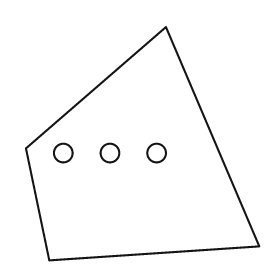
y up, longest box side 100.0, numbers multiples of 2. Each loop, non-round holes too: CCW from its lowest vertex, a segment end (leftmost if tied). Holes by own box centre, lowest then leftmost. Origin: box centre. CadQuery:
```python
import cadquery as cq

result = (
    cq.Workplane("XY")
    .moveTo(-40.0, -50.0)
    .lineTo(50.0, -44.0)
    .lineTo(10.0, 50.0)
    .lineTo(-50.0, -2.0)
    .close()
    .moveTo(-34.0, -4.0)
    .circle(4.0)
    .moveTo(-14.0, -4.0)
    .circle(4.0)
    .moveTo(6.0, -4.0)
    .circle(4.0)
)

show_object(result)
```